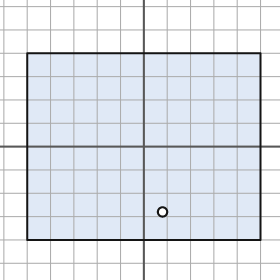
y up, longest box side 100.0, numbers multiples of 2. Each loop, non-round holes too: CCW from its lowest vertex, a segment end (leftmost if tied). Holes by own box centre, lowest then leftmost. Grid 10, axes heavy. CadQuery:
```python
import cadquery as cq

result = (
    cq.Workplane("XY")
    .moveTo(-50.0, -40.0)
    .lineTo(50.0, -40.0)
    .lineTo(50.0, 40.0)
    .lineTo(-50.0, 40.0)
    .close()
    .moveTo(8.0, -28.0)
    .circle(2.0)
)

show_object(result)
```